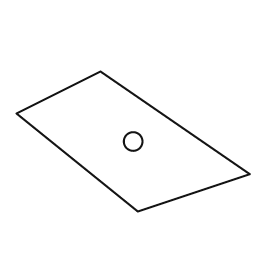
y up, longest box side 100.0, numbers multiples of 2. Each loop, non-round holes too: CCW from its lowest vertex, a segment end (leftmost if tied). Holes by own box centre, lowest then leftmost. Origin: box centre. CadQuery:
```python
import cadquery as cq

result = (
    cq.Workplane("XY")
    .moveTo(2.0, -30.0)
    .lineTo(50.0, -14.0)
    .lineTo(-14.0, 30.0)
    .lineTo(-50.0, 12.0)
    .close()
    .moveTo(0.0, 0.0)
    .circle(4.0)
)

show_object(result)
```